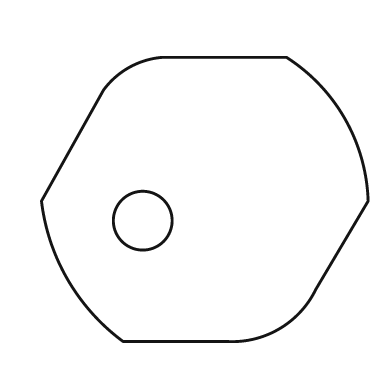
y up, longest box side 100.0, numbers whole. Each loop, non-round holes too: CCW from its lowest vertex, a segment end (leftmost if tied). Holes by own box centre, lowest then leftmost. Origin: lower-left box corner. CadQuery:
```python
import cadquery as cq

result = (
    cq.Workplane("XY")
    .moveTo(25.0, 0.0)
    .lineTo(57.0, 0.0)
    .threePointArc((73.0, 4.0), (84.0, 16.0))
    .lineTo(100.0, 43.0)
    .threePointArc((93.0, 68.0), (75.0, 87.0))
    .lineTo(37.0, 87.0)
    .threePointArc((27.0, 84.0), (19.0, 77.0))
    .lineTo(0.0, 43.0)
    .threePointArc((8.0, 19.0), (25.0, 0.0))
    .close()
    .moveTo(31.0, 37.0)
    .circle(9.0)
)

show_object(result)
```